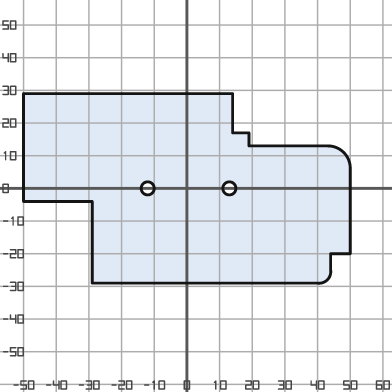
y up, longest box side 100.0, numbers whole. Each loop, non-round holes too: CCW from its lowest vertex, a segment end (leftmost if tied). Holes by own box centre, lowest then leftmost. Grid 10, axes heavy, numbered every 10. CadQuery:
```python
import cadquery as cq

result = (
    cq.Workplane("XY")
    .moveTo(-29.0, -29.0)
    .lineTo(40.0, -29.0)
    .threePointArc((43.0, -28.0), (44.0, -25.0))
    .lineTo(44.0, -20.0)
    .lineTo(50.0, -20.0)
    .lineTo(50.0, 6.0)
    .threePointArc((48.0, 11.0), (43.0, 13.0))
    .lineTo(19.0, 13.0)
    .lineTo(19.0, 17.0)
    .lineTo(14.0, 17.0)
    .lineTo(14.0, 29.0)
    .lineTo(-50.0, 29.0)
    .lineTo(-50.0, -4.0)
    .lineTo(-29.0, -4.0)
    .close()
    .moveTo(-12.0, 0.0)
    .circle(2.0)
    .moveTo(13.0, 0.0)
    .circle(2.0)
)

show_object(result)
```